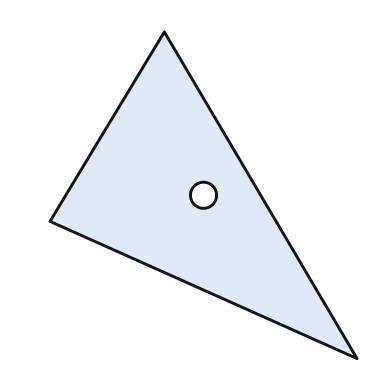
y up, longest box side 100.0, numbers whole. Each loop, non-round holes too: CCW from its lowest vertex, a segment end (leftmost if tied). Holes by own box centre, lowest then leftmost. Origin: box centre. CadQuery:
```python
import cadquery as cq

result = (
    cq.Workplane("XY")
    .moveTo(47.0, -50.0)
    .lineTo(-12.0, 50.0)
    .lineTo(-47.0, -8.0)
    .close()
    .moveTo(0.0, 0.0)
    .circle(4.0)
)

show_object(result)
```